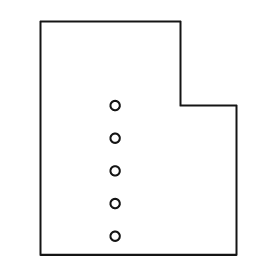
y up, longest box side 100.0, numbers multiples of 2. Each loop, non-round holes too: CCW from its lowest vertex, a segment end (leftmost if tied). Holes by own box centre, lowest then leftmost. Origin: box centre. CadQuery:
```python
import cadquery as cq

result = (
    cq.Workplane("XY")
    .moveTo(-42.0, -50.0)
    .lineTo(42.0, -50.0)
    .lineTo(42.0, 14.0)
    .lineTo(18.0, 14.0)
    .lineTo(18.0, 50.0)
    .lineTo(-42.0, 50.0)
    .close()
    .moveTo(-10.0, -42.0)
    .circle(2.0)
    .moveTo(-10.0, -28.0)
    .circle(2.0)
    .moveTo(-10.0, -14.0)
    .circle(2.0)
    .moveTo(-10.0, 0.0)
    .circle(2.0)
    .moveTo(-10.0, 14.0)
    .circle(2.0)
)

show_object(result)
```